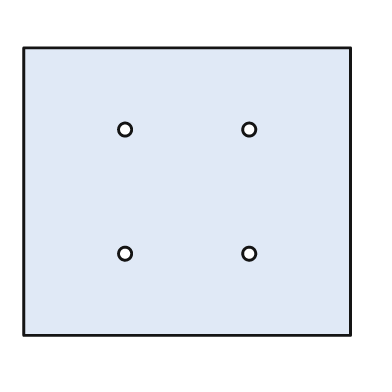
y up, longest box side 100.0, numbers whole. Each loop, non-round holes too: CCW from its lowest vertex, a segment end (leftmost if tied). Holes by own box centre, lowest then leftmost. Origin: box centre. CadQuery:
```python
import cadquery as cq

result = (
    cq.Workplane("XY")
    .moveTo(-50.0, -44.0)
    .lineTo(50.0, -44.0)
    .lineTo(50.0, 44.0)
    .lineTo(-50.0, 44.0)
    .close()
    .moveTo(-19.0, -19.0)
    .circle(2.0)
    .moveTo(19.0, -19.0)
    .circle(2.0)
    .moveTo(-19.0, 19.0)
    .circle(2.0)
    .moveTo(19.0, 19.0)
    .circle(2.0)
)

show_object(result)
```